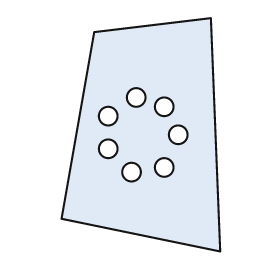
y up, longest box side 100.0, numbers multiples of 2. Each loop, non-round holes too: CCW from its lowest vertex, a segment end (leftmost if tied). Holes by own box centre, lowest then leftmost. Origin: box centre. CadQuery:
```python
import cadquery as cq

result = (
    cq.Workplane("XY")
    .moveTo(34.0, -50.0)
    .lineTo(30.0, 50.0)
    .lineTo(-20.0, 44.0)
    .lineTo(-34.0, -36.0)
    .close()
    .moveTo(-4.0, -16.0)
    .circle(4.0)
    .moveTo(10.0, -14.0)
    .circle(4.0)
    .moveTo(-14.0, -6.0)
    .circle(4.0)
    .moveTo(16.0, 0.0)
    .circle(4.0)
    .moveTo(-14.0, 8.0)
    .circle(4.0)
    .moveTo(10.0, 12.0)
    .circle(4.0)
    .moveTo(-2.0, 16.0)
    .circle(4.0)
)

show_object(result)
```